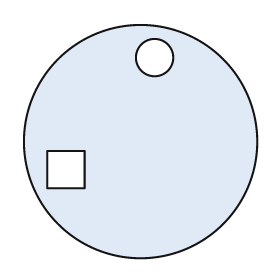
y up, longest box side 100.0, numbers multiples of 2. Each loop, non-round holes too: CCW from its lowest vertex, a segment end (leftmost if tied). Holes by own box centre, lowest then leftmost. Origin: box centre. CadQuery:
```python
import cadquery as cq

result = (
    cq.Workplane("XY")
    .moveTo(0.0, 0.0)
    .circle(50.0)
    .moveTo(-40.0, -20.0)
    .lineTo(-24.0, -20.0)
    .lineTo(-24.0, -4.0)
    .lineTo(-40.0, -4.0)
    .close()
    .moveTo(6.0, 36.0)
    .circle(8.0)
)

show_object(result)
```